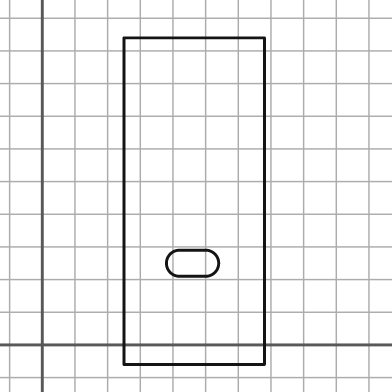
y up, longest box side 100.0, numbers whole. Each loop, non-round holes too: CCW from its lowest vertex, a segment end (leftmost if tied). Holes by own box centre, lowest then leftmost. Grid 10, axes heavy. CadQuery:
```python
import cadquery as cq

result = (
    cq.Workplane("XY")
    .moveTo(25.0, -6.0)
    .lineTo(68.0, -6.0)
    .lineTo(68.0, 94.0)
    .lineTo(25.0, 94.0)
    .close()
    .moveTo(42.0, 21.0)
    .lineTo(50.0, 21.0)
    .threePointArc((54.0, 25.0), (50.0, 29.0))
    .lineTo(42.0, 29.0)
    .threePointArc((38.0, 25.0), (42.0, 21.0))
    .close()
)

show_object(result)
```